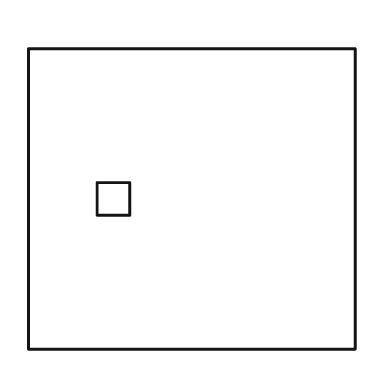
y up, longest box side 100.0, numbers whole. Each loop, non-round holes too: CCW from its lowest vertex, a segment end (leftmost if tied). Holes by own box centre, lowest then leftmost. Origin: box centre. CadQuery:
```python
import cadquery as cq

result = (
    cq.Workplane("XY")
    .moveTo(-50.0, -46.0)
    .lineTo(50.0, -46.0)
    .lineTo(50.0, 46.0)
    .lineTo(-50.0, 46.0)
    .close()
    .moveTo(-29.0, -5.0)
    .lineTo(-19.0, -5.0)
    .lineTo(-19.0, 5.0)
    .lineTo(-29.0, 5.0)
    .close()
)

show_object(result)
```